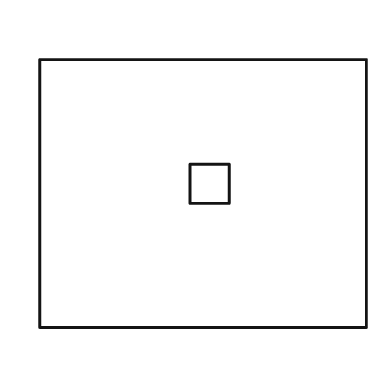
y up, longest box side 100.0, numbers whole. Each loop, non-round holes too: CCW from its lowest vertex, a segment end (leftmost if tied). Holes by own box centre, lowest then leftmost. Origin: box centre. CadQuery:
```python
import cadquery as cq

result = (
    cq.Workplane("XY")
    .moveTo(-50.0, -41.0)
    .lineTo(50.0, -41.0)
    .lineTo(50.0, 41.0)
    .lineTo(-50.0, 41.0)
    .close()
    .moveTo(-4.0, -3.0)
    .lineTo(8.0, -3.0)
    .lineTo(8.0, 9.0)
    .lineTo(-4.0, 9.0)
    .close()
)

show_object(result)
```